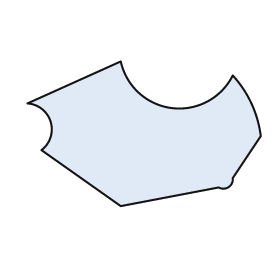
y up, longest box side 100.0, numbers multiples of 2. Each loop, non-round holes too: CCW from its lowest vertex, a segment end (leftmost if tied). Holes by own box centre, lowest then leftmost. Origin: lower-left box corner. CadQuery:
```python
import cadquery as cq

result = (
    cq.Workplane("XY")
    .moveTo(40.0, 0.0)
    .lineTo(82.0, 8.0)
    .threePointArc((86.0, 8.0), (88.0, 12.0))
    .lineTo(100.0, 30.0)
    .threePointArc((96.0, 44.0), (88.0, 56.0))
    .threePointArc((62.0, 42.0), (40.0, 62.0))
    .lineTo(0.0, 44.0)
    .threePointArc((10.0, 36.0), (6.0, 24.0))
    .close()
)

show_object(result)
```